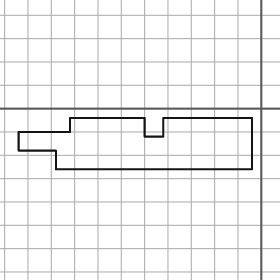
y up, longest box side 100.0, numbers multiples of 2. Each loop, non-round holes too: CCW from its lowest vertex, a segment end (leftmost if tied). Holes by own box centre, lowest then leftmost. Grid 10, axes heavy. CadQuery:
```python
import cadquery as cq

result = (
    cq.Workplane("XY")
    .moveTo(-88.0, -26.0)
    .lineTo(-4.0, -26.0)
    .lineTo(-4.0, -4.0)
    .lineTo(-42.0, -4.0)
    .lineTo(-42.0, -12.0)
    .lineTo(-50.0, -12.0)
    .lineTo(-50.0, -4.0)
    .lineTo(-82.0, -4.0)
    .lineTo(-82.0, -10.0)
    .lineTo(-104.0, -10.0)
    .lineTo(-104.0, -18.0)
    .lineTo(-88.0, -18.0)
    .close()
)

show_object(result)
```